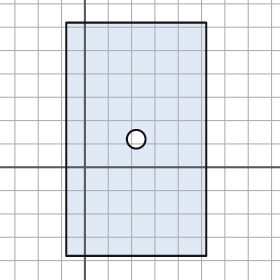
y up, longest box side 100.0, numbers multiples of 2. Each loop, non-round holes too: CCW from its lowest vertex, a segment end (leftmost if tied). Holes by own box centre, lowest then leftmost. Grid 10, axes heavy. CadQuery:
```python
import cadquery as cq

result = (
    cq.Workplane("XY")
    .moveTo(-8.0, -38.0)
    .lineTo(52.0, -38.0)
    .lineTo(52.0, 62.0)
    .lineTo(-8.0, 62.0)
    .close()
    .moveTo(22.0, 12.0)
    .circle(4.0)
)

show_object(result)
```